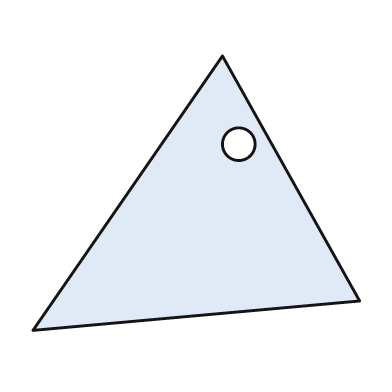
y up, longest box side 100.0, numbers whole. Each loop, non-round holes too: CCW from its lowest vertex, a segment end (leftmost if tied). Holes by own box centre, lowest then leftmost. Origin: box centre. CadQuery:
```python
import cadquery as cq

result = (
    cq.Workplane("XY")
    .moveTo(-50.0, -42.0)
    .lineTo(50.0, -33.0)
    .lineTo(8.0, 42.0)
    .close()
    .moveTo(13.0, 15.0)
    .circle(5.0)
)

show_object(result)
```